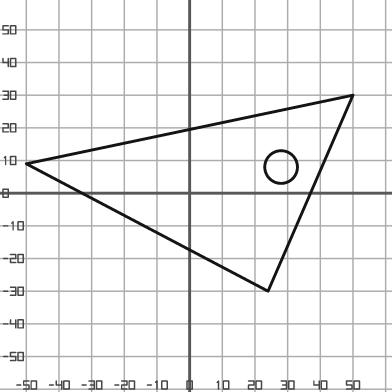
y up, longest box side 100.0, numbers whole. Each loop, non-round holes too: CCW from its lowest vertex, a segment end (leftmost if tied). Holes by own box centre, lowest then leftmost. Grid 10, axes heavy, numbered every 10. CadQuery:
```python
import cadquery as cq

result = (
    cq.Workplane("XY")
    .moveTo(24.0, -30.0)
    .lineTo(50.0, 30.0)
    .lineTo(-50.0, 9.0)
    .close()
    .moveTo(28.0, 8.0)
    .circle(5.0)
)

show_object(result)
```